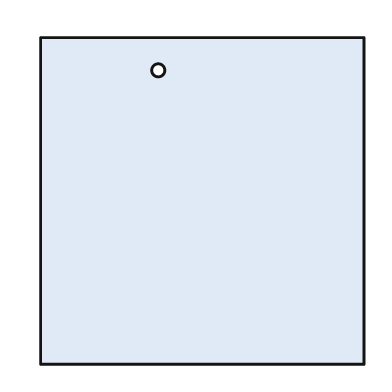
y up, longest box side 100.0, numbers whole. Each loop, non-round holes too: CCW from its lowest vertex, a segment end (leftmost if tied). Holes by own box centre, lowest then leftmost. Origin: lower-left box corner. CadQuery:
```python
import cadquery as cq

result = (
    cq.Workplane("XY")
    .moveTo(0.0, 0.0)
    .lineTo(99.0, 0.0)
    .lineTo(99.0, 100.0)
    .lineTo(0.0, 100.0)
    .close()
    .moveTo(36.0, 90.0)
    .circle(2.0)
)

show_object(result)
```